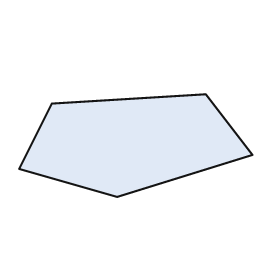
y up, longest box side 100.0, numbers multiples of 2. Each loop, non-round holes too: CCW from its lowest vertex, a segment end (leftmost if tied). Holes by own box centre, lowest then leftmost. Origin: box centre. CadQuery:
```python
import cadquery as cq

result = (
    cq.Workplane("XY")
    .moveTo(-8.0, -22.0)
    .lineTo(50.0, -4.0)
    .lineTo(30.0, 22.0)
    .lineTo(-36.0, 18.0)
    .lineTo(-50.0, -10.0)
    .close()
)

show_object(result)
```